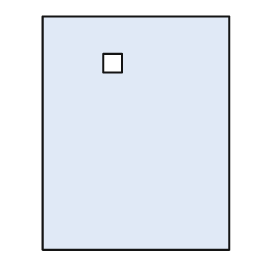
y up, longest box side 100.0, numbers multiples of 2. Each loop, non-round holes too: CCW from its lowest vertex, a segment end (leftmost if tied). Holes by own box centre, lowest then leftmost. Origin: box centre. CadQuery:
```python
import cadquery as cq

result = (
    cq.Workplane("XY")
    .moveTo(-40.0, -50.0)
    .lineTo(40.0, -50.0)
    .lineTo(40.0, 50.0)
    .lineTo(-40.0, 50.0)
    .close()
    .moveTo(-14.0, 26.0)
    .lineTo(-6.0, 26.0)
    .lineTo(-6.0, 34.0)
    .lineTo(-14.0, 34.0)
    .close()
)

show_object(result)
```